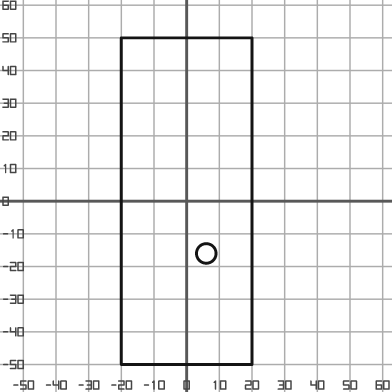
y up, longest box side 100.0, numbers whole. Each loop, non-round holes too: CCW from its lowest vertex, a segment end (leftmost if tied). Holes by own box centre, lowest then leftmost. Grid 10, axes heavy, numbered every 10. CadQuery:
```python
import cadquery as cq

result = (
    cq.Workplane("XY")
    .moveTo(-20.0, -50.0)
    .lineTo(20.0, -50.0)
    .lineTo(20.0, 50.0)
    .lineTo(-20.0, 50.0)
    .close()
    .moveTo(6.0, -16.0)
    .circle(3.0)
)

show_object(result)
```